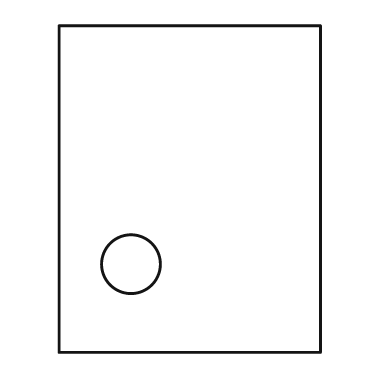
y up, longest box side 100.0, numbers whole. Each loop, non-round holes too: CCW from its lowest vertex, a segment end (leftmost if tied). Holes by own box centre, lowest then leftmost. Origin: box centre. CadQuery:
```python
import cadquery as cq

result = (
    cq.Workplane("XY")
    .moveTo(-40.0, -50.0)
    .lineTo(40.0, -50.0)
    .lineTo(40.0, 50.0)
    .lineTo(-40.0, 50.0)
    .close()
    .moveTo(-18.0, -23.0)
    .circle(9.0)
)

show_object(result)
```